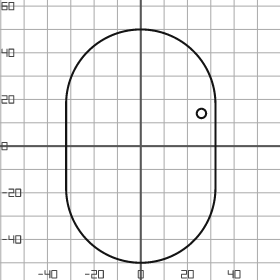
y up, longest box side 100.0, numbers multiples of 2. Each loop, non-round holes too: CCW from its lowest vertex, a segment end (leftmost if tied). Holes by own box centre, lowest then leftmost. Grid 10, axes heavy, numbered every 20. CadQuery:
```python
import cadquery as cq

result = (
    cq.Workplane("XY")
    .moveTo(-32.0, -18.0)
    .threePointArc((0.0, -50.0), (32.0, -18.0))
    .lineTo(32.0, 18.0)
    .threePointArc((0.0, 50.0), (-32.0, 18.0))
    .close()
    .moveTo(26.0, 14.0)
    .circle(2.0)
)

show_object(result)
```